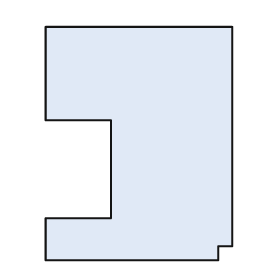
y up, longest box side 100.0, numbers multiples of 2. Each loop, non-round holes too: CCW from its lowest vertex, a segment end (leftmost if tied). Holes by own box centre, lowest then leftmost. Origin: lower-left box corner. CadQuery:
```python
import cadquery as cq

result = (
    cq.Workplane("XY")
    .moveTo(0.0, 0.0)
    .lineTo(74.0, 0.0)
    .lineTo(74.0, 6.0)
    .lineTo(80.0, 6.0)
    .lineTo(80.0, 100.0)
    .lineTo(0.0, 100.0)
    .lineTo(0.0, 60.0)
    .lineTo(28.0, 60.0)
    .lineTo(28.0, 18.0)
    .lineTo(0.0, 18.0)
    .close()
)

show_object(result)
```